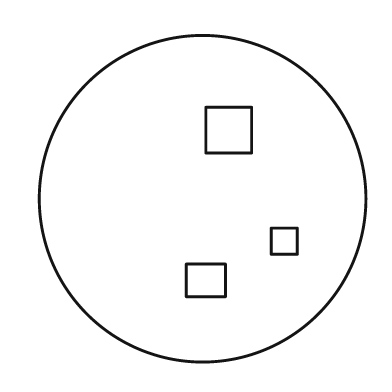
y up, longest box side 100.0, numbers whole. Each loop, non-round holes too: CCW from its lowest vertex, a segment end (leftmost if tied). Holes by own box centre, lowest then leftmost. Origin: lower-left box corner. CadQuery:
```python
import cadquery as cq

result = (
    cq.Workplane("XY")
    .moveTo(50.0, 50.0)
    .circle(50.0)
    .moveTo(45.0, 20.0)
    .lineTo(57.0, 20.0)
    .lineTo(57.0, 30.0)
    .lineTo(45.0, 30.0)
    .close()
    .moveTo(71.0, 33.0)
    .lineTo(79.0, 33.0)
    .lineTo(79.0, 41.0)
    .lineTo(71.0, 41.0)
    .close()
    .moveTo(51.0, 64.0)
    .lineTo(65.0, 64.0)
    .lineTo(65.0, 78.0)
    .lineTo(51.0, 78.0)
    .close()
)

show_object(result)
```